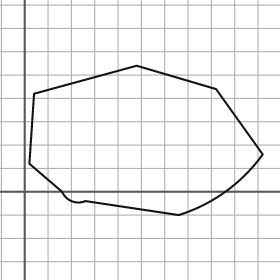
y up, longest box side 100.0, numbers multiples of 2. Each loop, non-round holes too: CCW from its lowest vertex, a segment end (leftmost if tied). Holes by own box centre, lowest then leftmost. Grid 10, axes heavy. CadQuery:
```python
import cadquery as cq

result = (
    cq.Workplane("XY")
    .moveTo(66.0, -10.0)
    .threePointArc((86.0, 0.0), (102.0, 16.0))
    .lineTo(82.0, 44.0)
    .lineTo(48.0, 54.0)
    .lineTo(4.0, 42.0)
    .lineTo(2.0, 12.0)
    .lineTo(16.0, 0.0)
    .threePointArc((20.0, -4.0), (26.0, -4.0))
    .close()
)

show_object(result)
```